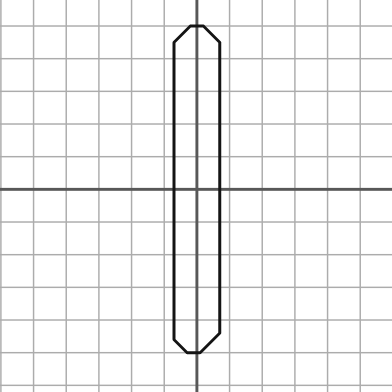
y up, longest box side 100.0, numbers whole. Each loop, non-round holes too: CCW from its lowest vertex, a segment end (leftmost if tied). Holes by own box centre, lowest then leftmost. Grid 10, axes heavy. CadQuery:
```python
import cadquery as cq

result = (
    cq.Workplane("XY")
    .moveTo(-3.0, -50.0)
    .lineTo(1.0, -50.0)
    .lineTo(7.0, -44.0)
    .lineTo(7.0, 45.0)
    .lineTo(2.0, 50.0)
    .lineTo(-2.0, 50.0)
    .lineTo(-7.0, 45.0)
    .lineTo(-7.0, -46.0)
    .close()
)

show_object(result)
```